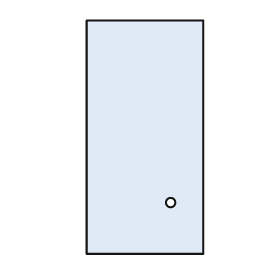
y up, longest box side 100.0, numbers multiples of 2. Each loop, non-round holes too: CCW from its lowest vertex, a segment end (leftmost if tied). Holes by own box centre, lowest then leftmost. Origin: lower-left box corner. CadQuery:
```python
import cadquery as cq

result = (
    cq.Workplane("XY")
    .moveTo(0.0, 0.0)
    .lineTo(50.0, 0.0)
    .lineTo(50.0, 100.0)
    .lineTo(0.0, 100.0)
    .close()
    .moveTo(36.0, 22.0)
    .circle(2.0)
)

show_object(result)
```